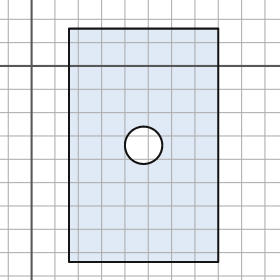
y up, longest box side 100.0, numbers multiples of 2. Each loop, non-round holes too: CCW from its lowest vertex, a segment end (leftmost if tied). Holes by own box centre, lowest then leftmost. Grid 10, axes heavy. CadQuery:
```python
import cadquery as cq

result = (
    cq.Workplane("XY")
    .moveTo(16.0, -84.0)
    .lineTo(80.0, -84.0)
    .lineTo(80.0, 16.0)
    .lineTo(16.0, 16.0)
    .close()
    .moveTo(48.0, -34.0)
    .circle(8.0)
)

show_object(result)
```